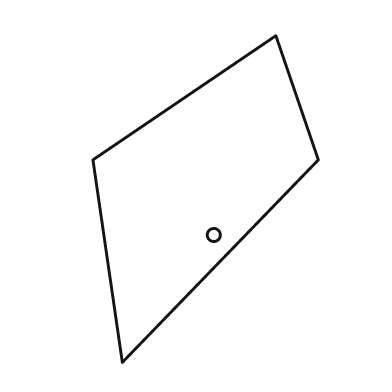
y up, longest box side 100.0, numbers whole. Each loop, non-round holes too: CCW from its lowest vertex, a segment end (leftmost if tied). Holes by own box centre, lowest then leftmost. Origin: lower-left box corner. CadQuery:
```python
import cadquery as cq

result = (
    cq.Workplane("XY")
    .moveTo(9.0, 0.0)
    .lineTo(69.0, 62.0)
    .lineTo(56.0, 100.0)
    .lineTo(0.0, 62.0)
    .close()
    .moveTo(37.0, 39.0)
    .circle(2.0)
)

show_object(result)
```